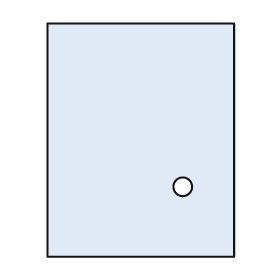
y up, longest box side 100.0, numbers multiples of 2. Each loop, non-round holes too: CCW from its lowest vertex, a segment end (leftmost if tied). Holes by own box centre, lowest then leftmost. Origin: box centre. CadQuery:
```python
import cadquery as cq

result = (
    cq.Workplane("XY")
    .moveTo(-40.0, -50.0)
    .lineTo(40.0, -50.0)
    .lineTo(40.0, 50.0)
    .lineTo(-40.0, 50.0)
    .close()
    .moveTo(18.0, -20.0)
    .circle(4.0)
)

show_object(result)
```